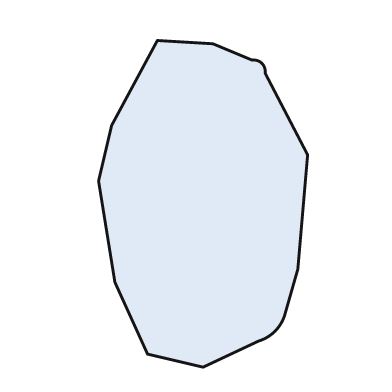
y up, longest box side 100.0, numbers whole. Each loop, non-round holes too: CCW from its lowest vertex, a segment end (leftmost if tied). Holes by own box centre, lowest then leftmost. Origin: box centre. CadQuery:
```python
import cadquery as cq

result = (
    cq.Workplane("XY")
    .moveTo(0.0, -50.0)
    .lineTo(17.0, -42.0)
    .threePointArc((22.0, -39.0), (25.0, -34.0))
    .lineTo(29.0, -20.0)
    .lineTo(32.0, 15.0)
    .lineTo(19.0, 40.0)
    .threePointArc((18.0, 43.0), (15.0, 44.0))
    .lineTo(3.0, 49.0)
    .lineTo(-14.0, 50.0)
    .lineTo(-28.0, 24.0)
    .lineTo(-32.0, 7.0)
    .lineTo(-27.0, -24.0)
    .lineTo(-17.0, -46.0)
    .close()
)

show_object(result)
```